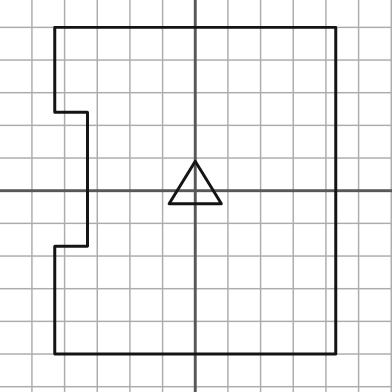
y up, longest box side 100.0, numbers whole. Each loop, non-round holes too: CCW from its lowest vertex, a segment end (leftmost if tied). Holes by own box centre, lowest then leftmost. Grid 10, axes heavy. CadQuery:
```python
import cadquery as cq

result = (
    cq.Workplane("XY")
    .moveTo(-43.0, -50.0)
    .lineTo(43.0, -50.0)
    .lineTo(43.0, 50.0)
    .lineTo(-43.0, 50.0)
    .lineTo(-43.0, 24.0)
    .lineTo(-33.0, 24.0)
    .lineTo(-33.0, -17.0)
    .lineTo(-43.0, -17.0)
    .close()
    .moveTo(-8.0, -4.0)
    .lineTo(8.0, -4.0)
    .lineTo(0.0, 9.0)
    .close()
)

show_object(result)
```